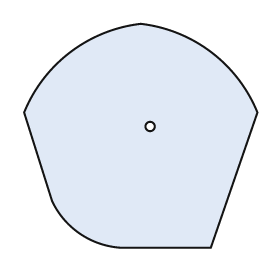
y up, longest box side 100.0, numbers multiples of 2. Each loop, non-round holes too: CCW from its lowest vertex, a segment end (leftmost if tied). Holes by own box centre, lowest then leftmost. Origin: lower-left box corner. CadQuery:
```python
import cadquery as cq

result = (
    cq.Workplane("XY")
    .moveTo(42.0, 0.0)
    .lineTo(80.0, 0.0)
    .lineTo(100.0, 58.0)
    .threePointArc((80.0, 84.0), (50.0, 96.0))
    .threePointArc((20.0, 84.0), (0.0, 58.0))
    .lineTo(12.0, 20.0)
    .threePointArc((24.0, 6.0), (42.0, 0.0))
    .close()
    .moveTo(54.0, 52.0)
    .circle(2.0)
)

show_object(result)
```